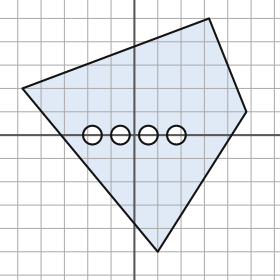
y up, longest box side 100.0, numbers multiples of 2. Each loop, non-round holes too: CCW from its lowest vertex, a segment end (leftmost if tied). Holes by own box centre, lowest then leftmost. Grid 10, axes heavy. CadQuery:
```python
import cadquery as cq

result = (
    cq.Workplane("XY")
    .moveTo(10.0, -50.0)
    .lineTo(48.0, 10.0)
    .lineTo(32.0, 50.0)
    .lineTo(-48.0, 20.0)
    .close()
    .moveTo(-18.0, 0.0)
    .circle(4.0)
    .moveTo(-6.0, 0.0)
    .circle(4.0)
    .moveTo(6.0, 0.0)
    .circle(4.0)
    .moveTo(18.0, 0.0)
    .circle(4.0)
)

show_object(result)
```